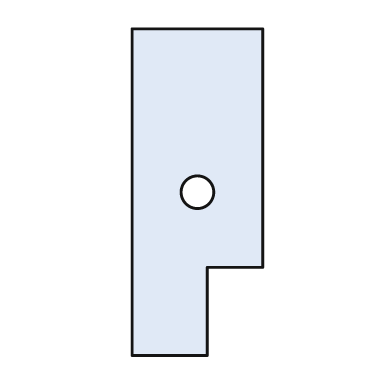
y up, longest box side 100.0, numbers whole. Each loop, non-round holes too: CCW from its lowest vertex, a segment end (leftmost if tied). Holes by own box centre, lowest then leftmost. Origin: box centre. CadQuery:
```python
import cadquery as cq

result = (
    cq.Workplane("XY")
    .moveTo(-20.0, -50.0)
    .lineTo(3.0, -50.0)
    .lineTo(3.0, -23.0)
    .lineTo(20.0, -23.0)
    .lineTo(20.0, 50.0)
    .lineTo(-20.0, 50.0)
    .close()
    .moveTo(0.0, 0.0)
    .circle(5.0)
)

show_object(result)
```